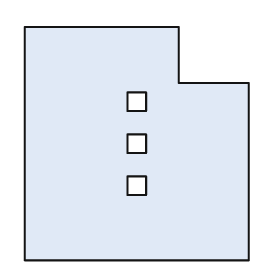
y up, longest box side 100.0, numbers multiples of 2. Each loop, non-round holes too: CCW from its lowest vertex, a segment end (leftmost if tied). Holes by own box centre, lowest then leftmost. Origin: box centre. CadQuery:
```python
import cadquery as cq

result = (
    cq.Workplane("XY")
    .moveTo(-48.0, -50.0)
    .lineTo(48.0, -50.0)
    .lineTo(48.0, 26.0)
    .lineTo(18.0, 26.0)
    .lineTo(18.0, 50.0)
    .lineTo(-48.0, 50.0)
    .close()
    .moveTo(-4.0, -22.0)
    .lineTo(4.0, -22.0)
    .lineTo(4.0, -14.0)
    .lineTo(-4.0, -14.0)
    .close()
    .moveTo(-4.0, -4.0)
    .lineTo(4.0, -4.0)
    .lineTo(4.0, 4.0)
    .lineTo(-4.0, 4.0)
    .close()
    .moveTo(-4.0, 14.0)
    .lineTo(4.0, 14.0)
    .lineTo(4.0, 22.0)
    .lineTo(-4.0, 22.0)
    .close()
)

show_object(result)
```